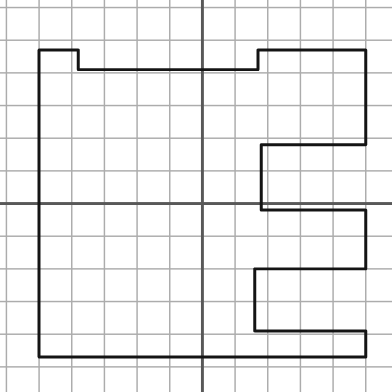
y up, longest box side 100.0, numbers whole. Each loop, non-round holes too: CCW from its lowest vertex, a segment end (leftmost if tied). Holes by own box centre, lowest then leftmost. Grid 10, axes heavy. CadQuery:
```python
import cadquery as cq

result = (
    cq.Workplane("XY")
    .moveTo(-50.0, -47.0)
    .lineTo(50.0, -47.0)
    .lineTo(50.0, -39.0)
    .lineTo(16.0, -39.0)
    .lineTo(16.0, -20.0)
    .lineTo(50.0, -20.0)
    .lineTo(50.0, -2.0)
    .lineTo(18.0, -2.0)
    .lineTo(18.0, 18.0)
    .lineTo(50.0, 18.0)
    .lineTo(50.0, 47.0)
    .lineTo(17.0, 47.0)
    .lineTo(17.0, 41.0)
    .lineTo(-38.0, 41.0)
    .lineTo(-38.0, 47.0)
    .lineTo(-50.0, 47.0)
    .close()
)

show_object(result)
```